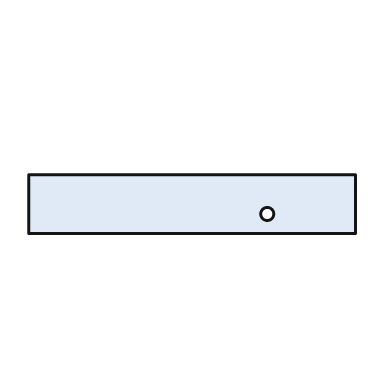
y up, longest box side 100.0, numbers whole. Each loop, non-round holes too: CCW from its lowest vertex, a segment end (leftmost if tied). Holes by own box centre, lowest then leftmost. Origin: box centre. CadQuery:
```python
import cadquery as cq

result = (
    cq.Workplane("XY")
    .moveTo(-50.0, -9.0)
    .lineTo(50.0, -9.0)
    .lineTo(50.0, 9.0)
    .lineTo(-50.0, 9.0)
    .close()
    .moveTo(23.0, -3.0)
    .circle(2.0)
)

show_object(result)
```